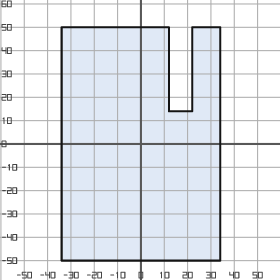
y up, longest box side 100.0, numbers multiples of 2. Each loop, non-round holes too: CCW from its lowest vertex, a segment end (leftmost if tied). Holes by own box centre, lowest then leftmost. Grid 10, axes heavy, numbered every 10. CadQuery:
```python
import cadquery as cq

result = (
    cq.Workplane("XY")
    .moveTo(-34.0, -50.0)
    .lineTo(34.0, -50.0)
    .lineTo(34.0, 50.0)
    .lineTo(22.0, 50.0)
    .lineTo(22.0, 14.0)
    .lineTo(12.0, 14.0)
    .lineTo(12.0, 50.0)
    .lineTo(-34.0, 50.0)
    .close()
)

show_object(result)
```